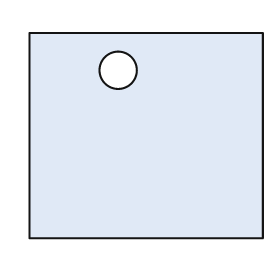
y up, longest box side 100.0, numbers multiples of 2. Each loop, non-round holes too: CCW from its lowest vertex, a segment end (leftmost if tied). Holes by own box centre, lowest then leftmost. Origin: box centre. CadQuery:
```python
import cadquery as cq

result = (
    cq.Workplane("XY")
    .moveTo(-50.0, -44.0)
    .lineTo(50.0, -44.0)
    .lineTo(50.0, 44.0)
    .lineTo(-50.0, 44.0)
    .close()
    .moveTo(-12.0, 28.0)
    .circle(8.0)
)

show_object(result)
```